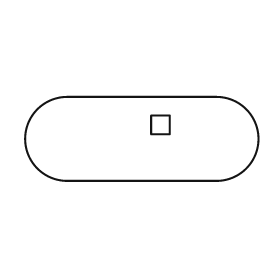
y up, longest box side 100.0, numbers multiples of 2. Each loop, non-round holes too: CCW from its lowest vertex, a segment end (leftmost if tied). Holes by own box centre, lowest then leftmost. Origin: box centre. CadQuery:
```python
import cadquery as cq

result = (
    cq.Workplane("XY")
    .moveTo(-32.0, -18.0)
    .lineTo(32.0, -18.0)
    .threePointArc((50.0, 0.0), (32.0, 18.0))
    .lineTo(-32.0, 18.0)
    .threePointArc((-50.0, 0.0), (-32.0, -18.0))
    .close()
    .moveTo(4.0, 2.0)
    .lineTo(12.0, 2.0)
    .lineTo(12.0, 10.0)
    .lineTo(4.0, 10.0)
    .close()
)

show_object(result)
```